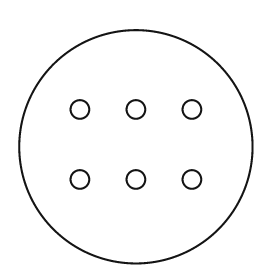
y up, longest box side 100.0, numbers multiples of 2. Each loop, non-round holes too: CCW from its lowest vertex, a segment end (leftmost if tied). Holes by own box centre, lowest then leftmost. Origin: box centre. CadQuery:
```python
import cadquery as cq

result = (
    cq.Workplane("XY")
    .moveTo(0.0, 0.0)
    .circle(50.0)
    .moveTo(-24.0, -14.0)
    .circle(4.0)
    .moveTo(0.0, -14.0)
    .circle(4.0)
    .moveTo(24.0, -14.0)
    .circle(4.0)
    .moveTo(-24.0, 16.0)
    .circle(4.0)
    .moveTo(0.0, 16.0)
    .circle(4.0)
    .moveTo(24.0, 16.0)
    .circle(4.0)
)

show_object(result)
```